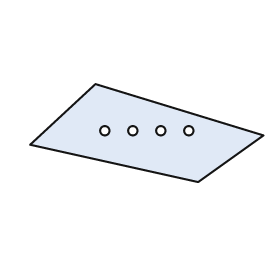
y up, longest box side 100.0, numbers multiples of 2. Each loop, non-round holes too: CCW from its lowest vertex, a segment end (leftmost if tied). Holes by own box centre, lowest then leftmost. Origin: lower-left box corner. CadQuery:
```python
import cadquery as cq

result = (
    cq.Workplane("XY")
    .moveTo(72.0, 0.0)
    .lineTo(100.0, 20.0)
    .lineTo(28.0, 42.0)
    .lineTo(0.0, 16.0)
    .close()
    .moveTo(32.0, 22.0)
    .circle(2.0)
    .moveTo(44.0, 22.0)
    .circle(2.0)
    .moveTo(56.0, 22.0)
    .circle(2.0)
    .moveTo(68.0, 22.0)
    .circle(2.0)
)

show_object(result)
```